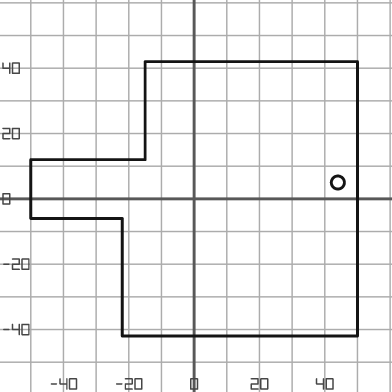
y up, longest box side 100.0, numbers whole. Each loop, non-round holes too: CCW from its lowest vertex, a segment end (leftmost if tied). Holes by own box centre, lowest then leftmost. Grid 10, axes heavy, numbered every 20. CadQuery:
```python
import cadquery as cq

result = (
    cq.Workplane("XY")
    .moveTo(-22.0, -42.0)
    .lineTo(50.0, -42.0)
    .lineTo(50.0, 42.0)
    .lineTo(-15.0, 42.0)
    .lineTo(-15.0, 12.0)
    .lineTo(-50.0, 12.0)
    .lineTo(-50.0, -6.0)
    .lineTo(-22.0, -6.0)
    .close()
    .moveTo(44.0, 5.0)
    .circle(2.0)
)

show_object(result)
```